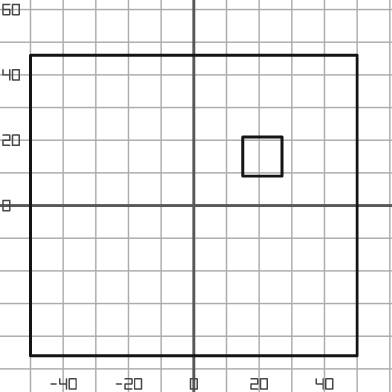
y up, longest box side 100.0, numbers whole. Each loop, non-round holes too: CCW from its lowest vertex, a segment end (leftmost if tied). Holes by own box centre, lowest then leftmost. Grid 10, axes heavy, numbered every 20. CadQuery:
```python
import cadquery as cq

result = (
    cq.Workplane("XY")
    .moveTo(-50.0, -46.0)
    .lineTo(50.0, -46.0)
    .lineTo(50.0, 46.0)
    .lineTo(-50.0, 46.0)
    .close()
    .moveTo(15.0, 9.0)
    .lineTo(27.0, 9.0)
    .lineTo(27.0, 21.0)
    .lineTo(15.0, 21.0)
    .close()
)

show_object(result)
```